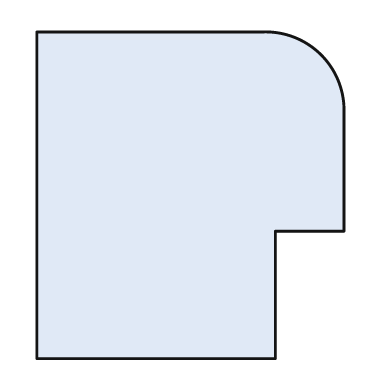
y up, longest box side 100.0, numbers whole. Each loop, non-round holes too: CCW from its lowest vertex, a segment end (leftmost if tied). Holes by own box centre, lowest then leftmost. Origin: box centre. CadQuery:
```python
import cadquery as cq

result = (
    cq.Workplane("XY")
    .moveTo(-47.0, -50.0)
    .lineTo(26.0, -50.0)
    .lineTo(26.0, -11.0)
    .lineTo(47.0, -11.0)
    .lineTo(47.0, 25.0)
    .threePointArc((40.0, 43.0), (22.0, 50.0))
    .lineTo(-47.0, 50.0)
    .close()
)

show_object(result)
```